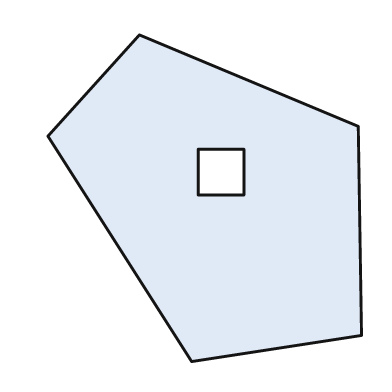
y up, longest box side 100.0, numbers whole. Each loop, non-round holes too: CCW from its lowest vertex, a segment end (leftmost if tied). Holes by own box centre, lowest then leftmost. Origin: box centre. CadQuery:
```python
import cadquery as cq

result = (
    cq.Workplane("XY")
    .moveTo(-4.0, -50.0)
    .lineTo(48.0, -42.0)
    .lineTo(47.0, 22.0)
    .lineTo(-20.0, 50.0)
    .lineTo(-48.0, 19.0)
    .close()
    .moveTo(-2.0, 1.0)
    .lineTo(12.0, 1.0)
    .lineTo(12.0, 15.0)
    .lineTo(-2.0, 15.0)
    .close()
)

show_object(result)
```